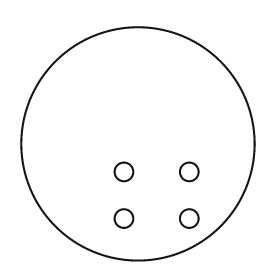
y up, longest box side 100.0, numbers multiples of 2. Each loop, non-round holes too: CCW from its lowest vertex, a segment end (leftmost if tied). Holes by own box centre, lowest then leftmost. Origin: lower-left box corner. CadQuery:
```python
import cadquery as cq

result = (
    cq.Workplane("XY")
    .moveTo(50.0, 50.0)
    .circle(50.0)
    .moveTo(44.0, 18.0)
    .circle(4.0)
    .moveTo(72.0, 18.0)
    .circle(4.0)
    .moveTo(44.0, 38.0)
    .circle(4.0)
    .moveTo(72.0, 38.0)
    .circle(4.0)
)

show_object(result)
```